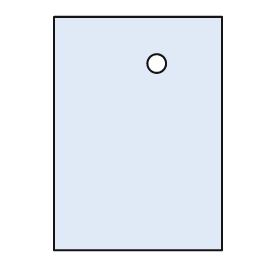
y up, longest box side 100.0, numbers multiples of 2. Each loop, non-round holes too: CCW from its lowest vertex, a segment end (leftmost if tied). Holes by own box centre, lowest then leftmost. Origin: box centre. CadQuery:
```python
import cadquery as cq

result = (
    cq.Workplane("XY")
    .moveTo(-36.0, -50.0)
    .lineTo(36.0, -50.0)
    .lineTo(36.0, 50.0)
    .lineTo(-36.0, 50.0)
    .close()
    .moveTo(8.0, 30.0)
    .circle(4.0)
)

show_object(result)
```